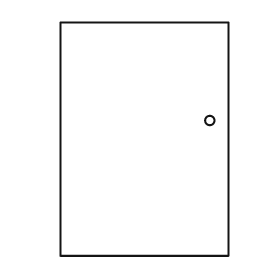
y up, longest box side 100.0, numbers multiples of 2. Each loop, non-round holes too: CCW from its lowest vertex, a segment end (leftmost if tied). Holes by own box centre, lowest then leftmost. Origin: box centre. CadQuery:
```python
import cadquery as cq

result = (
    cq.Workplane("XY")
    .moveTo(-36.0, -50.0)
    .lineTo(36.0, -50.0)
    .lineTo(36.0, 50.0)
    .lineTo(-36.0, 50.0)
    .close()
    .moveTo(28.0, 8.0)
    .circle(2.0)
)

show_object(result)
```